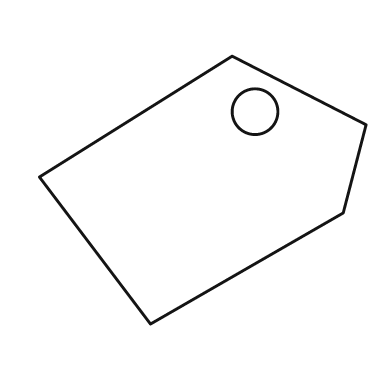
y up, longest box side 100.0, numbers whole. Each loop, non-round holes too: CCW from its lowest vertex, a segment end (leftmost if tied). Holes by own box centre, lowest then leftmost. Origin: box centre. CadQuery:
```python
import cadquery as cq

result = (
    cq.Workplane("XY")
    .moveTo(-16.0, -41.0)
    .lineTo(43.0, -7.0)
    .lineTo(50.0, 20.0)
    .lineTo(9.0, 41.0)
    .lineTo(-50.0, 4.0)
    .close()
    .moveTo(16.0, 24.0)
    .circle(7.0)
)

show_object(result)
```